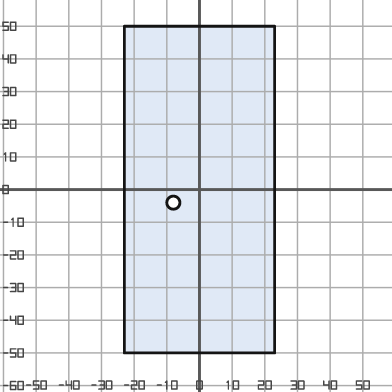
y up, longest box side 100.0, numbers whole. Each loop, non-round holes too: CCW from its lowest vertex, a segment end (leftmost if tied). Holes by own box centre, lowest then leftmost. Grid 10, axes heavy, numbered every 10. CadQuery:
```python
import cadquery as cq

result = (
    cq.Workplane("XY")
    .moveTo(-23.0, -50.0)
    .lineTo(23.0, -50.0)
    .lineTo(23.0, 50.0)
    .lineTo(-23.0, 50.0)
    .close()
    .moveTo(-8.0, -4.0)
    .circle(2.0)
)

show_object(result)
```